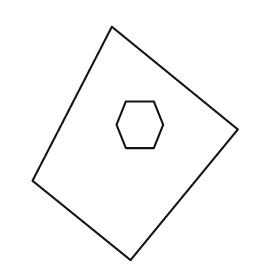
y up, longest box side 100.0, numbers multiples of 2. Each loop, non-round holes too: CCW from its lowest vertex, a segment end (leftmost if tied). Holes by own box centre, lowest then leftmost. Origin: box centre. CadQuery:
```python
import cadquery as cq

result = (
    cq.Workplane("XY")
    .moveTo(-2.0, -50.0)
    .lineTo(44.0, 6.0)
    .lineTo(-10.0, 50.0)
    .lineTo(-44.0, -16.0)
    .close()
    .moveTo(-4.0, -2.0)
    .lineTo(8.0, -2.0)
    .lineTo(12.0, 8.0)
    .lineTo(8.0, 18.0)
    .lineTo(-4.0, 18.0)
    .lineTo(-8.0, 8.0)
    .close()
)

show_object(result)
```